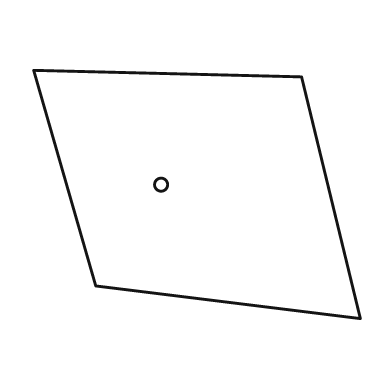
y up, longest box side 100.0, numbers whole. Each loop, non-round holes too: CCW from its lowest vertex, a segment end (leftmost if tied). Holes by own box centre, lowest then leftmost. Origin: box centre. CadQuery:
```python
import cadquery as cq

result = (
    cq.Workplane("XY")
    .moveTo(50.0, -38.0)
    .lineTo(32.0, 36.0)
    .lineTo(-50.0, 38.0)
    .lineTo(-31.0, -28.0)
    .close()
    .moveTo(-11.0, 3.0)
    .circle(2.0)
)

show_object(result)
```